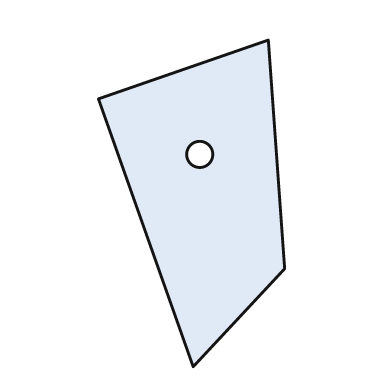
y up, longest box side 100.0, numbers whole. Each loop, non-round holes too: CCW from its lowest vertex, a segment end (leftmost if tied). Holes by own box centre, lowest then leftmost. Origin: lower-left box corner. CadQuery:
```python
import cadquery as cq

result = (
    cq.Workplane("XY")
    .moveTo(29.0, 0.0)
    .lineTo(57.0, 30.0)
    .lineTo(52.0, 100.0)
    .lineTo(0.0, 82.0)
    .close()
    .moveTo(31.0, 65.0)
    .circle(4.0)
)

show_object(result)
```